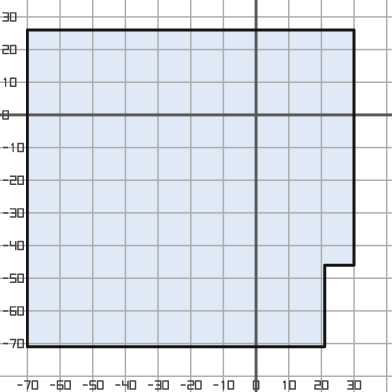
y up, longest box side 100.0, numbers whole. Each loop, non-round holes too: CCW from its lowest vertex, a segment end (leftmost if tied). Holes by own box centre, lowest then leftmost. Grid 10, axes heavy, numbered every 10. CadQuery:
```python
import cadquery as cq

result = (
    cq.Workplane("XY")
    .moveTo(-70.0, -71.0)
    .lineTo(21.0, -71.0)
    .lineTo(21.0, -46.0)
    .lineTo(30.0, -46.0)
    .lineTo(30.0, 26.0)
    .lineTo(-70.0, 26.0)
    .close()
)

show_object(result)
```